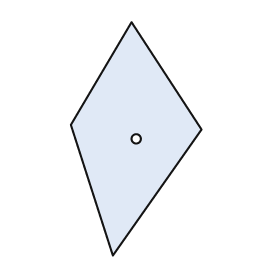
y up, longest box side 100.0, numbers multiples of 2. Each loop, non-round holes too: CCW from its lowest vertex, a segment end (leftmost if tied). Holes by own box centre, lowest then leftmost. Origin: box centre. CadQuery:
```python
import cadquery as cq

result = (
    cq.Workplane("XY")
    .moveTo(-10.0, -50.0)
    .lineTo(28.0, 4.0)
    .lineTo(-2.0, 50.0)
    .lineTo(-28.0, 6.0)
    .close()
    .moveTo(0.0, 0.0)
    .circle(2.0)
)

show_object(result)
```